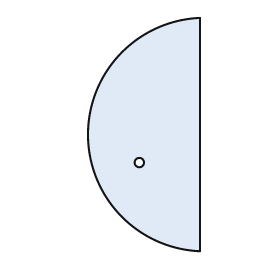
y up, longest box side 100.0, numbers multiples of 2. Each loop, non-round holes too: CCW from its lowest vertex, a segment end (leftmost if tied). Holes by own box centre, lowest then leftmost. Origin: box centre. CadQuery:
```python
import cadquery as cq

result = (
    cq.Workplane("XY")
    .moveTo(24.0, -50.0)
    .lineTo(24.0, 50.0)
    .threePointArc((-24.0, 0.0), (24.0, -50.0))
    .close()
    .moveTo(-2.0, -12.0)
    .circle(2.0)
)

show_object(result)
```